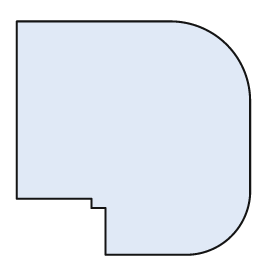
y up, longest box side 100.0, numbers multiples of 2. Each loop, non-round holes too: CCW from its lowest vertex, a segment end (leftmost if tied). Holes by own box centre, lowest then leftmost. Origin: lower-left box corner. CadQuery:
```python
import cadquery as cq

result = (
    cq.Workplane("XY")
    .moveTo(38.0, 0.0)
    .lineTo(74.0, 0.0)
    .threePointArc((92.0, 8.0), (100.0, 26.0))
    .lineTo(100.0, 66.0)
    .threePointArc((90.0, 90.0), (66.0, 100.0))
    .lineTo(0.0, 100.0)
    .lineTo(0.0, 24.0)
    .lineTo(32.0, 24.0)
    .lineTo(32.0, 20.0)
    .lineTo(38.0, 20.0)
    .close()
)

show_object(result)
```